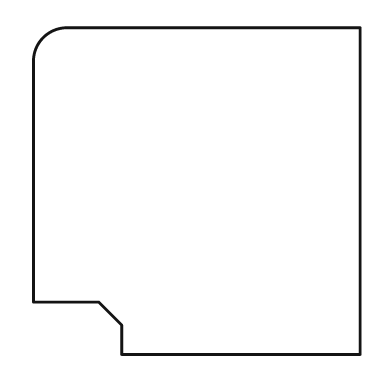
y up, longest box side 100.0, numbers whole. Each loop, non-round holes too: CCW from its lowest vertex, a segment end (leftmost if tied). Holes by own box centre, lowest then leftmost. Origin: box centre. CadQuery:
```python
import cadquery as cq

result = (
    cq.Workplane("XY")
    .moveTo(-23.0, -50.0)
    .lineTo(50.0, -50.0)
    .lineTo(50.0, 50.0)
    .lineTo(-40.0, 50.0)
    .threePointArc((-47.0, 47.0), (-50.0, 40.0))
    .lineTo(-50.0, -34.0)
    .lineTo(-30.0, -34.0)
    .lineTo(-23.0, -41.0)
    .close()
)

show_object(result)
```